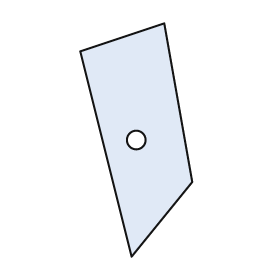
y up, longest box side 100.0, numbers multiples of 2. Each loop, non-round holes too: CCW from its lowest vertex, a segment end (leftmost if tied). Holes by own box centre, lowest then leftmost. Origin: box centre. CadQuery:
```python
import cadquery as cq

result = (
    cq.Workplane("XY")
    .moveTo(-2.0, -50.0)
    .lineTo(24.0, -18.0)
    .lineTo(12.0, 50.0)
    .lineTo(-24.0, 38.0)
    .close()
    .moveTo(0.0, 0.0)
    .circle(4.0)
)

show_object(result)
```